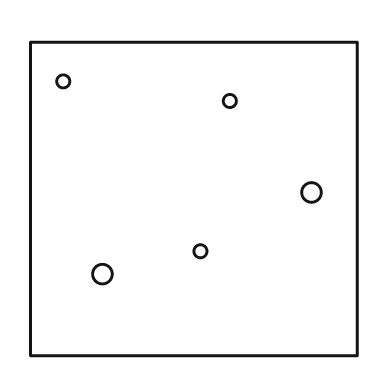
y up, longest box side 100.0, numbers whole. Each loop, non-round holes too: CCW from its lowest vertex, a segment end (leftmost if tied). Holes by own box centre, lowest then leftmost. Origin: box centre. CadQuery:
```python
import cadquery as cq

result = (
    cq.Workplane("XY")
    .moveTo(-50.0, -48.0)
    .lineTo(50.0, -48.0)
    .lineTo(50.0, 48.0)
    .lineTo(-50.0, 48.0)
    .close()
    .moveTo(-28.0, -23.0)
    .circle(3.0)
    .moveTo(2.0, -16.0)
    .circle(2.0)
    .moveTo(36.0, 2.0)
    .circle(3.0)
    .moveTo(11.0, 30.0)
    .circle(2.0)
    .moveTo(-40.0, 36.0)
    .circle(2.0)
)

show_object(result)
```